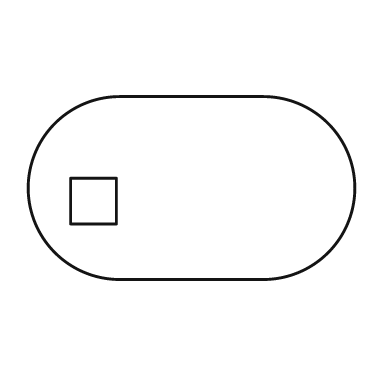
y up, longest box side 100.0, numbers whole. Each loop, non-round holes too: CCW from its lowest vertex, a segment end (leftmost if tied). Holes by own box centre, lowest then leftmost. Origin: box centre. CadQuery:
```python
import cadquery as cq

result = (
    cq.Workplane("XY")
    .moveTo(-22.0, -28.0)
    .lineTo(22.0, -28.0)
    .threePointArc((50.0, 0.0), (22.0, 28.0))
    .lineTo(-22.0, 28.0)
    .threePointArc((-50.0, 0.0), (-22.0, -28.0))
    .close()
    .moveTo(-37.0, -11.0)
    .lineTo(-23.0, -11.0)
    .lineTo(-23.0, 3.0)
    .lineTo(-37.0, 3.0)
    .close()
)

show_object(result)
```